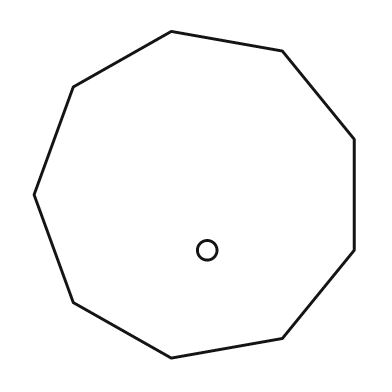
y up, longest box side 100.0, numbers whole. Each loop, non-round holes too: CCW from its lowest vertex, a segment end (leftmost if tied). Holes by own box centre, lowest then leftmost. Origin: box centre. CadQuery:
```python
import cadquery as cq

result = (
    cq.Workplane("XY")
    .moveTo(-7.0, -50.0)
    .lineTo(27.0, -44.0)
    .lineTo(49.0, -17.0)
    .lineTo(49.0, 17.0)
    .lineTo(27.0, 44.0)
    .lineTo(-7.0, 50.0)
    .lineTo(-37.0, 33.0)
    .lineTo(-49.0, 0.0)
    .lineTo(-37.0, -33.0)
    .close()
    .moveTo(4.0, -17.0)
    .circle(3.0)
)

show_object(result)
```